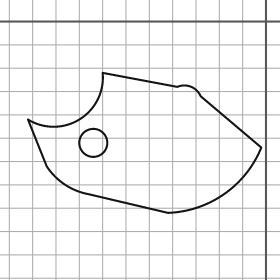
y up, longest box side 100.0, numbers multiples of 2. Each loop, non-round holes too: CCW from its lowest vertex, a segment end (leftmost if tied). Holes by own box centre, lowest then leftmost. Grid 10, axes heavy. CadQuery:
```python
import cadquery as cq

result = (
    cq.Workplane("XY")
    .moveTo(-42.0, -82.0)
    .threePointArc((-18.0, -74.0), (-2.0, -54.0))
    .lineTo(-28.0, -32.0)
    .threePointArc((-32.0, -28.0), (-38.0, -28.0))
    .lineTo(-70.0, -22.0)
    .threePointArc((-80.0, -42.0), (-102.0, -42.0))
    .lineTo(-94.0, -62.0)
    .threePointArc((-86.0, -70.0), (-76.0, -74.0))
    .close()
    .moveTo(-74.0, -52.0)
    .circle(6.0)
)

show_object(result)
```